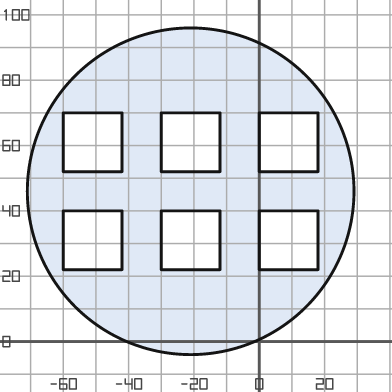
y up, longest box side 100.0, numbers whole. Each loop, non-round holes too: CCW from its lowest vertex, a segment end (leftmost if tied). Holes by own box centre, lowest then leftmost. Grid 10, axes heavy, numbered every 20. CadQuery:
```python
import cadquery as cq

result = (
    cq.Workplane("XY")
    .moveTo(-21.0, 46.0)
    .circle(50.0)
    .moveTo(-60.0, 22.0)
    .lineTo(-42.0, 22.0)
    .lineTo(-42.0, 40.0)
    .lineTo(-60.0, 40.0)
    .close()
    .moveTo(-30.0, 22.0)
    .lineTo(-12.0, 22.0)
    .lineTo(-12.0, 40.0)
    .lineTo(-30.0, 40.0)
    .close()
    .moveTo(0.0, 22.0)
    .lineTo(18.0, 22.0)
    .lineTo(18.0, 40.0)
    .lineTo(0.0, 40.0)
    .close()
    .moveTo(-60.0, 52.0)
    .lineTo(-42.0, 52.0)
    .lineTo(-42.0, 70.0)
    .lineTo(-60.0, 70.0)
    .close()
    .moveTo(-30.0, 52.0)
    .lineTo(-12.0, 52.0)
    .lineTo(-12.0, 70.0)
    .lineTo(-30.0, 70.0)
    .close()
    .moveTo(0.0, 52.0)
    .lineTo(18.0, 52.0)
    .lineTo(18.0, 70.0)
    .lineTo(0.0, 70.0)
    .close()
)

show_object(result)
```